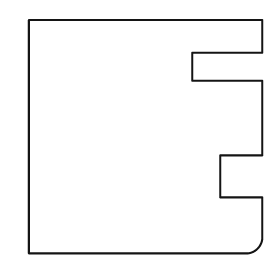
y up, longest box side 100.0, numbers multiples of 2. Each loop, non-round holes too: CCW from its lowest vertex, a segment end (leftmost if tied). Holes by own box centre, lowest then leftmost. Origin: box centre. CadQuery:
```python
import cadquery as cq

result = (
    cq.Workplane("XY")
    .moveTo(-50.0, -50.0)
    .lineTo(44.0, -50.0)
    .threePointArc((48.0, -48.0), (50.0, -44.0))
    .lineTo(50.0, -26.0)
    .lineTo(32.0, -26.0)
    .lineTo(32.0, -8.0)
    .lineTo(50.0, -8.0)
    .lineTo(50.0, 24.0)
    .lineTo(20.0, 24.0)
    .lineTo(20.0, 36.0)
    .lineTo(50.0, 36.0)
    .lineTo(50.0, 50.0)
    .lineTo(-50.0, 50.0)
    .close()
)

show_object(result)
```